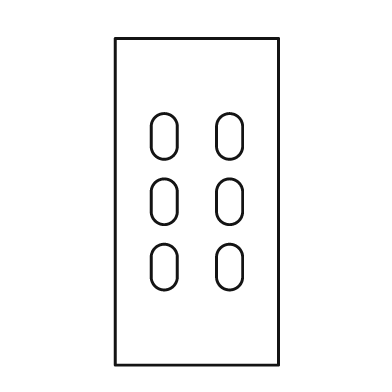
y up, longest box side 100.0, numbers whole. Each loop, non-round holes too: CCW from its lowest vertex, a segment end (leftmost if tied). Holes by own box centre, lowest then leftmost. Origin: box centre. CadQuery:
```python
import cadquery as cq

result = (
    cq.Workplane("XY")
    .moveTo(-25.0, -50.0)
    .lineTo(25.0, -50.0)
    .lineTo(25.0, 50.0)
    .lineTo(-25.0, 50.0)
    .close()
    .moveTo(-14.0, -23.0)
    .threePointArc((-10.0, -27.0), (-6.0, -23.0))
    .lineTo(-6.0, -17.0)
    .threePointArc((-10.0, -13.0), (-14.0, -17.0))
    .close()
    .moveTo(6.0, -23.0)
    .threePointArc((10.0, -27.0), (14.0, -23.0))
    .lineTo(14.0, -17.0)
    .threePointArc((10.0, -13.0), (6.0, -17.0))
    .close()
    .moveTo(-14.0, -3.0)
    .threePointArc((-10.0, -7.0), (-6.0, -3.0))
    .lineTo(-6.0, 3.0)
    .threePointArc((-10.0, 7.0), (-14.0, 3.0))
    .close()
    .moveTo(6.0, -3.0)
    .threePointArc((10.0, -7.0), (14.0, -3.0))
    .lineTo(14.0, 3.0)
    .threePointArc((10.0, 7.0), (6.0, 3.0))
    .close()
    .moveTo(-14.0, 17.0)
    .threePointArc((-10.0, 13.0), (-6.0, 17.0))
    .lineTo(-6.0, 23.0)
    .threePointArc((-10.0, 27.0), (-14.0, 23.0))
    .close()
    .moveTo(6.0, 17.0)
    .threePointArc((10.0, 13.0), (14.0, 17.0))
    .lineTo(14.0, 23.0)
    .threePointArc((10.0, 27.0), (6.0, 23.0))
    .close()
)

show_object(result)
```